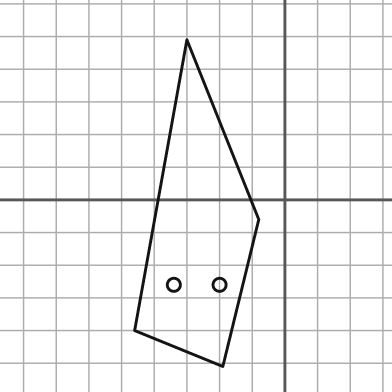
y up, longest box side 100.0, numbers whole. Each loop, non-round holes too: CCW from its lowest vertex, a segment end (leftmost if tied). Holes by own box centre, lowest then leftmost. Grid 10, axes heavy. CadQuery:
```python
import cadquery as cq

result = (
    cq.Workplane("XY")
    .moveTo(-19.0, -51.0)
    .lineTo(-8.0, -6.0)
    .lineTo(-30.0, 49.0)
    .lineTo(-46.0, -40.0)
    .close()
    .moveTo(-34.0, -26.0)
    .circle(2.0)
    .moveTo(-20.0, -26.0)
    .circle(2.0)
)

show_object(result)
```